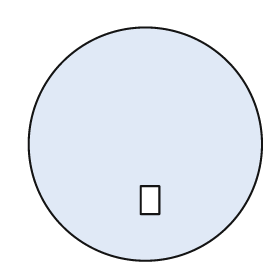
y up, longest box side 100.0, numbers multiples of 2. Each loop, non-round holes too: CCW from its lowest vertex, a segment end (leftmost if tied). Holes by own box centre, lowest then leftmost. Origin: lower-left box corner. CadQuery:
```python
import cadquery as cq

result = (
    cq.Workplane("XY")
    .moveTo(50.0, 50.0)
    .circle(50.0)
    .moveTo(48.0, 20.0)
    .lineTo(56.0, 20.0)
    .lineTo(56.0, 32.0)
    .lineTo(48.0, 32.0)
    .close()
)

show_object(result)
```